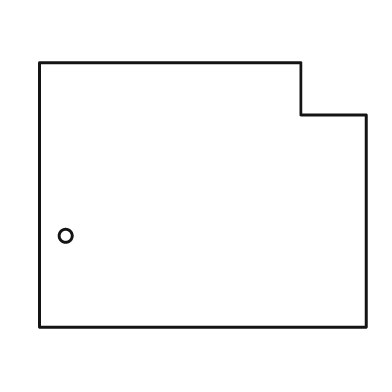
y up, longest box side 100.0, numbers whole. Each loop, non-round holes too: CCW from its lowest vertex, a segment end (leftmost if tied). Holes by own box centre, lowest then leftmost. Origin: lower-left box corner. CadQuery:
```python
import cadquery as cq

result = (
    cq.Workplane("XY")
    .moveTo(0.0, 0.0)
    .lineTo(100.0, 0.0)
    .lineTo(100.0, 65.0)
    .lineTo(80.0, 65.0)
    .lineTo(80.0, 81.0)
    .lineTo(0.0, 81.0)
    .close()
    .moveTo(8.0, 28.0)
    .circle(2.0)
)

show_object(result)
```